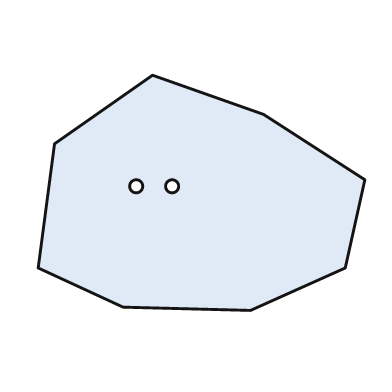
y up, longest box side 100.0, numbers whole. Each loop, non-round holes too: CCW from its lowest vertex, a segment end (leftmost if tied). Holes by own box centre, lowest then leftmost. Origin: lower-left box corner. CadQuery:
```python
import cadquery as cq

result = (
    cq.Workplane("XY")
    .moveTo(65.0, 0.0)
    .lineTo(94.0, 13.0)
    .lineTo(100.0, 40.0)
    .lineTo(69.0, 60.0)
    .lineTo(35.0, 72.0)
    .lineTo(5.0, 51.0)
    .lineTo(0.0, 13.0)
    .lineTo(26.0, 1.0)
    .close()
    .moveTo(30.0, 38.0)
    .circle(2.0)
    .moveTo(41.0, 38.0)
    .circle(2.0)
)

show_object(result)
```